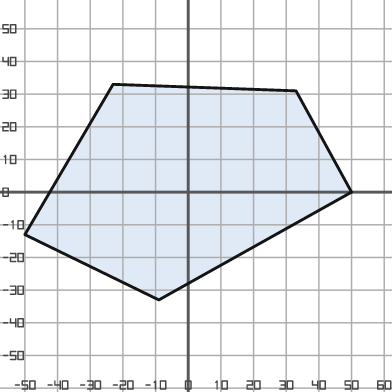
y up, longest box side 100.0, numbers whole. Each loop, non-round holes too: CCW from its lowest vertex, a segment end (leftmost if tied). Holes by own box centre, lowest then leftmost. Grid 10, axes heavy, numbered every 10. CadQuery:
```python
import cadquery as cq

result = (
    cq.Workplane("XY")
    .moveTo(-9.0, -33.0)
    .lineTo(50.0, 0.0)
    .lineTo(33.0, 31.0)
    .lineTo(-23.0, 33.0)
    .lineTo(-50.0, -13.0)
    .close()
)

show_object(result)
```